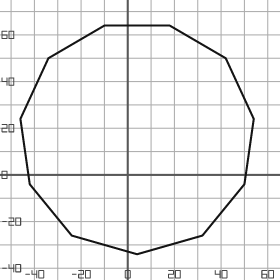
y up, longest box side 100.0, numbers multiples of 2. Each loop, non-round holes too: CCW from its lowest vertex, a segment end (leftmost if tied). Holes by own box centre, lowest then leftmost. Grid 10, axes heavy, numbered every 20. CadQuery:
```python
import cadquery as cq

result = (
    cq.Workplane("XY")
    .moveTo(4.0, -34.0)
    .lineTo(32.0, -26.0)
    .lineTo(50.0, -4.0)
    .lineTo(54.0, 24.0)
    .lineTo(42.0, 50.0)
    .lineTo(18.0, 64.0)
    .lineTo(-10.0, 64.0)
    .lineTo(-34.0, 50.0)
    .lineTo(-46.0, 24.0)
    .lineTo(-42.0, -4.0)
    .lineTo(-24.0, -26.0)
    .close()
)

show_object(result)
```